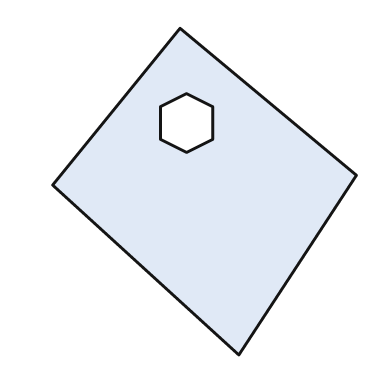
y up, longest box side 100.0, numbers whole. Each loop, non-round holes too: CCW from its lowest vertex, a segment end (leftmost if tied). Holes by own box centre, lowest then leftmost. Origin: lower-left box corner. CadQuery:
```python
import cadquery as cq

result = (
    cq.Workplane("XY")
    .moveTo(57.0, 0.0)
    .lineTo(93.0, 55.0)
    .lineTo(39.0, 100.0)
    .lineTo(0.0, 52.0)
    .close()
    .moveTo(41.0, 62.0)
    .lineTo(49.0, 66.0)
    .lineTo(49.0, 76.0)
    .lineTo(41.0, 80.0)
    .lineTo(33.0, 76.0)
    .lineTo(33.0, 66.0)
    .close()
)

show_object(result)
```